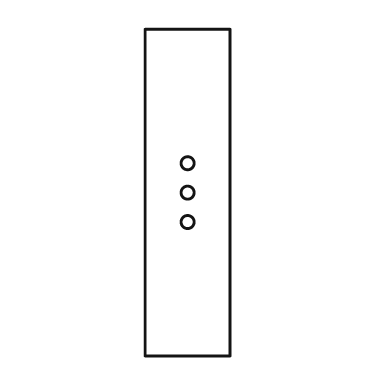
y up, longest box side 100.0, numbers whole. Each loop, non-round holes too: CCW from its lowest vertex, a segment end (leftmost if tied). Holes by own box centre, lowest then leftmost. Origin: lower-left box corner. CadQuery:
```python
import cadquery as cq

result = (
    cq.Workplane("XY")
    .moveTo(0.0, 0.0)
    .lineTo(26.0, 0.0)
    .lineTo(26.0, 100.0)
    .lineTo(0.0, 100.0)
    .close()
    .moveTo(13.0, 41.0)
    .circle(2.0)
    .moveTo(13.0, 50.0)
    .circle(2.0)
    .moveTo(13.0, 59.0)
    .circle(2.0)
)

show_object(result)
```